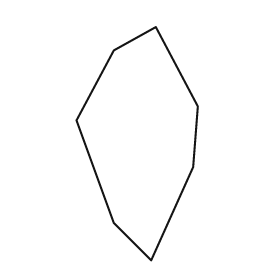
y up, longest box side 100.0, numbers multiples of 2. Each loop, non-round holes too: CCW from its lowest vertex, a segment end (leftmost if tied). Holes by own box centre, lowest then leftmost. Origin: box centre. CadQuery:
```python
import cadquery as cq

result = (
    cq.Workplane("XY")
    .moveTo(6.0, -50.0)
    .lineTo(24.0, -10.0)
    .lineTo(26.0, 16.0)
    .lineTo(8.0, 50.0)
    .lineTo(-10.0, 40.0)
    .lineTo(-26.0, 10.0)
    .lineTo(-10.0, -34.0)
    .close()
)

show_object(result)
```